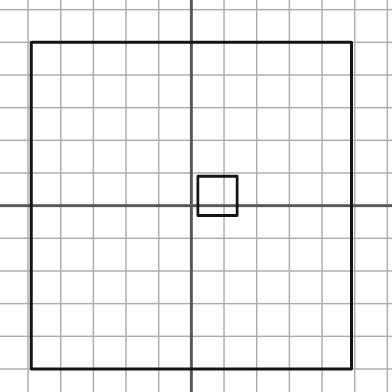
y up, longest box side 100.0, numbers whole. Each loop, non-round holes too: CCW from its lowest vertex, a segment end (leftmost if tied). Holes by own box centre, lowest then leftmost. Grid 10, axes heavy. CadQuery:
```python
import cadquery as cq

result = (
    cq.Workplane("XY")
    .moveTo(-49.0, -50.0)
    .lineTo(49.0, -50.0)
    .lineTo(49.0, 50.0)
    .lineTo(-49.0, 50.0)
    .close()
    .moveTo(2.0, -3.0)
    .lineTo(14.0, -3.0)
    .lineTo(14.0, 9.0)
    .lineTo(2.0, 9.0)
    .close()
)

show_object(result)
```